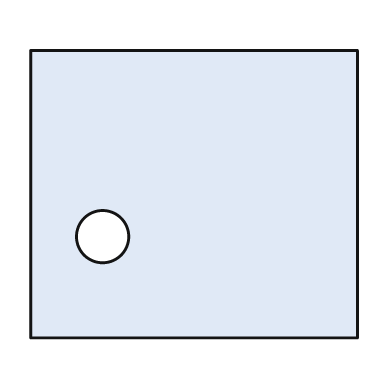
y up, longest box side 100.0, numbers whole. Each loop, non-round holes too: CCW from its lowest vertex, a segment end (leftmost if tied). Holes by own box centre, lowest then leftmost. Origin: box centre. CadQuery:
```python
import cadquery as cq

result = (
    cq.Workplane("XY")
    .moveTo(-50.0, -44.0)
    .lineTo(50.0, -44.0)
    .lineTo(50.0, 44.0)
    .lineTo(-50.0, 44.0)
    .close()
    .moveTo(-28.0, -13.0)
    .circle(8.0)
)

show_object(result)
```